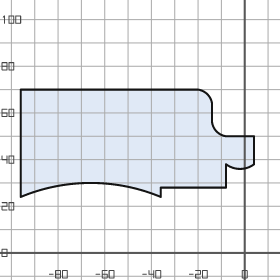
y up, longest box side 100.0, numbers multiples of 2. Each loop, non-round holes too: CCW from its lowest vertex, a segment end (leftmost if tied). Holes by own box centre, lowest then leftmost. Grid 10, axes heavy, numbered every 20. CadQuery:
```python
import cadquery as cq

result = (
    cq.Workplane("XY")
    .moveTo(-96.0, 24.0)
    .threePointArc((-66.0, 30.0), (-36.0, 24.0))
    .lineTo(-36.0, 28.0)
    .lineTo(-8.0, 28.0)
    .lineTo(-8.0, 38.0)
    .threePointArc((-2.0, 36.0), (4.0, 38.0))
    .lineTo(4.0, 50.0)
    .lineTo(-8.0, 50.0)
    .threePointArc((-12.0, 52.0), (-14.0, 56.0))
    .lineTo(-14.0, 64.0)
    .threePointArc((-16.0, 68.0), (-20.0, 70.0))
    .lineTo(-96.0, 70.0)
    .close()
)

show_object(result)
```